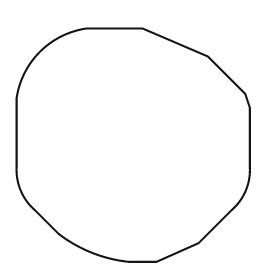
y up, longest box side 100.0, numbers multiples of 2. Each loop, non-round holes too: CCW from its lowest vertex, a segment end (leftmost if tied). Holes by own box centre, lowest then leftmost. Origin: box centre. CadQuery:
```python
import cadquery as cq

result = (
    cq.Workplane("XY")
    .moveTo(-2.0, -50.0)
    .lineTo(10.0, -50.0)
    .lineTo(28.0, -42.0)
    .lineTo(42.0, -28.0)
    .threePointArc((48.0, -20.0), (50.0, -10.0))
    .lineTo(50.0, 16.0)
    .lineTo(48.0, 22.0)
    .lineTo(32.0, 38.0)
    .lineTo(4.0, 50.0)
    .lineTo(-20.0, 50.0)
    .threePointArc((-40.0, 40.0), (-50.0, 20.0))
    .lineTo(-50.0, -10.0)
    .threePointArc((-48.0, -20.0), (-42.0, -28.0))
    .lineTo(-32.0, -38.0)
    .threePointArc((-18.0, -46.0), (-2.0, -50.0))
    .close()
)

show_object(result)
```